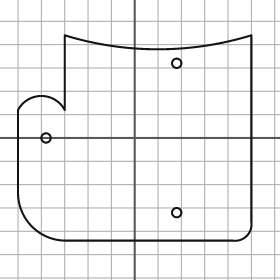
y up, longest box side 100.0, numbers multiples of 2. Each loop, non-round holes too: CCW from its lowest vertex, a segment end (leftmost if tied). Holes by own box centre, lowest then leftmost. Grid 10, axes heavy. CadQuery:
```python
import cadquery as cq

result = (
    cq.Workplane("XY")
    .moveTo(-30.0, -44.0)
    .lineTo(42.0, -44.0)
    .threePointArc((48.0, -42.0), (50.0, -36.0))
    .lineTo(50.0, 44.0)
    .threePointArc((10.0, 38.0), (-30.0, 44.0))
    .lineTo(-30.0, 12.0)
    .threePointArc((-40.0, 18.0), (-50.0, 12.0))
    .lineTo(-50.0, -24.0)
    .threePointArc((-44.0, -38.0), (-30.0, -44.0))
    .close()
    .moveTo(18.0, -32.0)
    .circle(2.0)
    .moveTo(-38.0, 0.0)
    .circle(2.0)
    .moveTo(18.0, 32.0)
    .circle(2.0)
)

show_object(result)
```